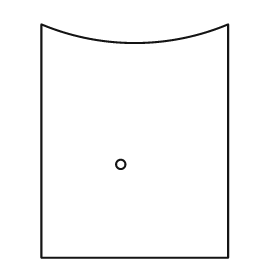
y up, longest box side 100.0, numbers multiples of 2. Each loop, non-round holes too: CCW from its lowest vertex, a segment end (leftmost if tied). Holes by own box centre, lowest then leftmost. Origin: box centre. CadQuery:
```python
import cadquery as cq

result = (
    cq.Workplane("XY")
    .moveTo(-40.0, -50.0)
    .lineTo(40.0, -50.0)
    .lineTo(40.0, 50.0)
    .threePointArc((0.0, 42.0), (-40.0, 50.0))
    .close()
    .moveTo(-6.0, -10.0)
    .circle(2.0)
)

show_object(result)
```